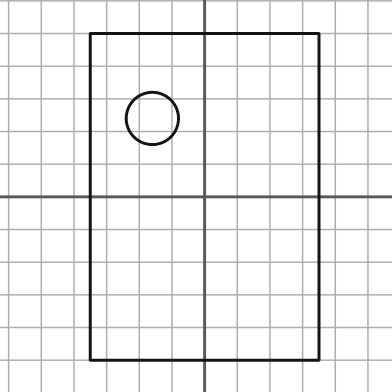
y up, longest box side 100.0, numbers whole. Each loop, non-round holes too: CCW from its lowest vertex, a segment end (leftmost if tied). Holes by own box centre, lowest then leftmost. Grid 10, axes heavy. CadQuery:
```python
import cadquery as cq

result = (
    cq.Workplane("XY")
    .moveTo(-35.0, -50.0)
    .lineTo(35.0, -50.0)
    .lineTo(35.0, 50.0)
    .lineTo(-35.0, 50.0)
    .close()
    .moveTo(-16.0, 24.0)
    .circle(8.0)
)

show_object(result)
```